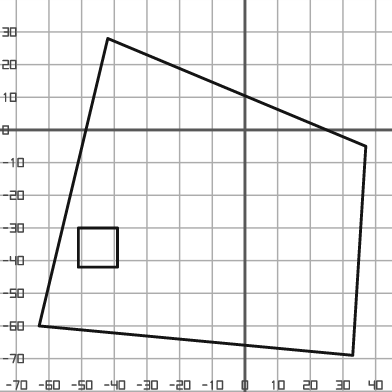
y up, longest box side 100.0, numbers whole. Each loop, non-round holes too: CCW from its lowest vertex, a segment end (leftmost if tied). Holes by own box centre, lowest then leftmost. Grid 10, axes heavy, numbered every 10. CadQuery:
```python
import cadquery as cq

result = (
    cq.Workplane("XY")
    .moveTo(33.0, -69.0)
    .lineTo(37.0, -5.0)
    .lineTo(-42.0, 28.0)
    .lineTo(-63.0, -60.0)
    .close()
    .moveTo(-51.0, -42.0)
    .lineTo(-39.0, -42.0)
    .lineTo(-39.0, -30.0)
    .lineTo(-51.0, -30.0)
    .close()
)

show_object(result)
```